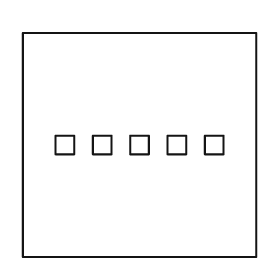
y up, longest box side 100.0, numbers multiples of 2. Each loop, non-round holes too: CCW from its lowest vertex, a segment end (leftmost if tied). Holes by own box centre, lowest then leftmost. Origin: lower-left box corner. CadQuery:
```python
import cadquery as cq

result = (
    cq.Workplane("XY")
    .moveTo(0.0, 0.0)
    .lineTo(100.0, 0.0)
    .lineTo(100.0, 96.0)
    .lineTo(0.0, 96.0)
    .close()
    .moveTo(14.0, 44.0)
    .lineTo(22.0, 44.0)
    .lineTo(22.0, 52.0)
    .lineTo(14.0, 52.0)
    .close()
    .moveTo(30.0, 44.0)
    .lineTo(38.0, 44.0)
    .lineTo(38.0, 52.0)
    .lineTo(30.0, 52.0)
    .close()
    .moveTo(46.0, 44.0)
    .lineTo(54.0, 44.0)
    .lineTo(54.0, 52.0)
    .lineTo(46.0, 52.0)
    .close()
    .moveTo(62.0, 44.0)
    .lineTo(70.0, 44.0)
    .lineTo(70.0, 52.0)
    .lineTo(62.0, 52.0)
    .close()
    .moveTo(78.0, 44.0)
    .lineTo(86.0, 44.0)
    .lineTo(86.0, 52.0)
    .lineTo(78.0, 52.0)
    .close()
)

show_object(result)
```